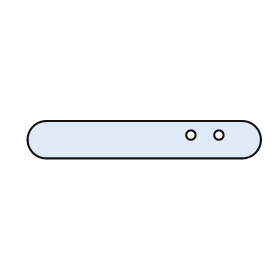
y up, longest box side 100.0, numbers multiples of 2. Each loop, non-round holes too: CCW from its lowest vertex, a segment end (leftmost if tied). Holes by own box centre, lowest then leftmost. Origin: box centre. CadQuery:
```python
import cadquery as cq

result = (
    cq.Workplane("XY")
    .moveTo(-42.0, -8.0)
    .lineTo(42.0, -8.0)
    .threePointArc((50.0, 0.0), (42.0, 8.0))
    .lineTo(-42.0, 8.0)
    .threePointArc((-50.0, 0.0), (-42.0, -8.0))
    .close()
    .moveTo(20.0, 2.0)
    .circle(2.0)
    .moveTo(32.0, 2.0)
    .circle(2.0)
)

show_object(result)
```